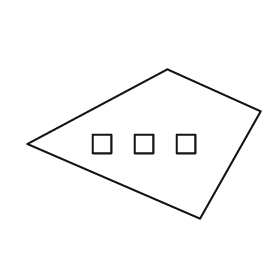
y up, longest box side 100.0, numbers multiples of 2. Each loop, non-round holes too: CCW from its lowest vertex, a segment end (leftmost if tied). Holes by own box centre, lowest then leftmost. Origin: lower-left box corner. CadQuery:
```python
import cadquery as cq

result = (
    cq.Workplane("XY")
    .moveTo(74.0, 0.0)
    .lineTo(100.0, 46.0)
    .lineTo(60.0, 64.0)
    .lineTo(0.0, 32.0)
    .close()
    .moveTo(28.0, 28.0)
    .lineTo(36.0, 28.0)
    .lineTo(36.0, 36.0)
    .lineTo(28.0, 36.0)
    .close()
    .moveTo(46.0, 28.0)
    .lineTo(54.0, 28.0)
    .lineTo(54.0, 36.0)
    .lineTo(46.0, 36.0)
    .close()
    .moveTo(64.0, 28.0)
    .lineTo(72.0, 28.0)
    .lineTo(72.0, 36.0)
    .lineTo(64.0, 36.0)
    .close()
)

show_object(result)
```